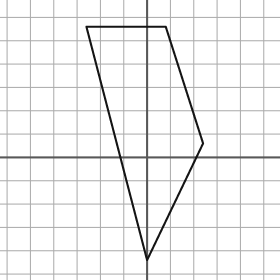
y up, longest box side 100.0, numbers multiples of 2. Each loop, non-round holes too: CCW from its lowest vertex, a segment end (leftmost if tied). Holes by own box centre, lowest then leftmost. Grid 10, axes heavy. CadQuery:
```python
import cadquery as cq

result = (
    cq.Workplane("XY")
    .moveTo(0.0, -44.0)
    .lineTo(24.0, 6.0)
    .lineTo(8.0, 56.0)
    .lineTo(-26.0, 56.0)
    .close()
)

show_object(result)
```